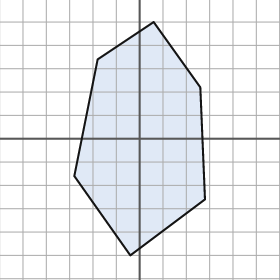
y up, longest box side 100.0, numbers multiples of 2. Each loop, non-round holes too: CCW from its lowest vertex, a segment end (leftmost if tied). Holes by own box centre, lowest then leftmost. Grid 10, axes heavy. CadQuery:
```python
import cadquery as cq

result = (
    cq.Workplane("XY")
    .moveTo(-4.0, -50.0)
    .lineTo(28.0, -26.0)
    .lineTo(26.0, 22.0)
    .lineTo(6.0, 50.0)
    .lineTo(-18.0, 34.0)
    .lineTo(-28.0, -16.0)
    .close()
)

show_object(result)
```